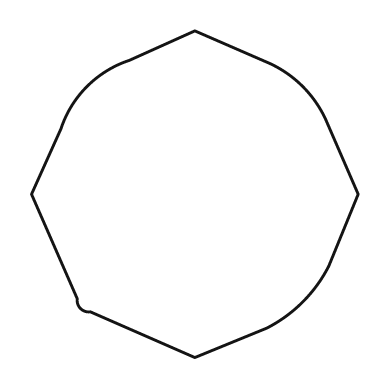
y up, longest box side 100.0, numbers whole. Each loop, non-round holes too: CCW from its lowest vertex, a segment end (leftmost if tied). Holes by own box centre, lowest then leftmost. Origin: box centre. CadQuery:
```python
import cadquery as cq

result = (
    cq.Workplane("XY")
    .moveTo(0.0, -50.0)
    .lineTo(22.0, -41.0)
    .threePointArc((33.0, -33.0), (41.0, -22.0))
    .lineTo(50.0, 0.0)
    .lineTo(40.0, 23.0)
    .threePointArc((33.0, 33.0), (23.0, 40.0))
    .lineTo(0.0, 50.0)
    .lineTo(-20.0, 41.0)
    .threePointArc((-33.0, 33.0), (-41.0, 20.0))
    .lineTo(-50.0, 0.0)
    .lineTo(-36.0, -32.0)
    .threePointArc((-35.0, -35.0), (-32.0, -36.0))
    .close()
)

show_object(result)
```